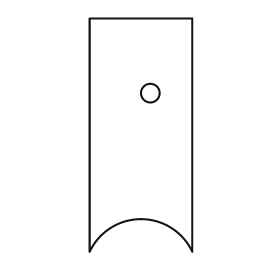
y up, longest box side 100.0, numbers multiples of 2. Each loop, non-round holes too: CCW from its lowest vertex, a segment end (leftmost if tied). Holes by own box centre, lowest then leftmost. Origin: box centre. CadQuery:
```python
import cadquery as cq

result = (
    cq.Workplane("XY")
    .moveTo(-22.0, -50.0)
    .threePointArc((0.0, -36.0), (22.0, -50.0))
    .lineTo(22.0, 50.0)
    .lineTo(-22.0, 50.0)
    .close()
    .moveTo(4.0, 18.0)
    .circle(4.0)
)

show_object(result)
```